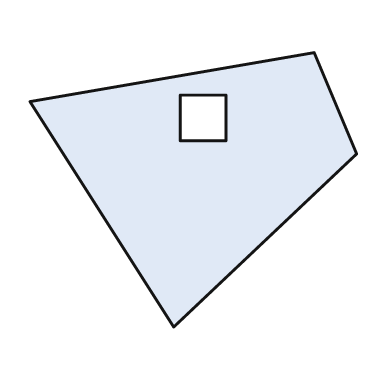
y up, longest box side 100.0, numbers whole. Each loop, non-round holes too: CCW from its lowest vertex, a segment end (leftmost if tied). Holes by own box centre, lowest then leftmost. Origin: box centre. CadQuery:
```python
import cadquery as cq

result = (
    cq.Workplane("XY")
    .moveTo(-6.0, -42.0)
    .lineTo(50.0, 11.0)
    .lineTo(37.0, 42.0)
    .lineTo(-50.0, 27.0)
    .close()
    .moveTo(-4.0, 15.0)
    .lineTo(10.0, 15.0)
    .lineTo(10.0, 29.0)
    .lineTo(-4.0, 29.0)
    .close()
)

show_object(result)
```